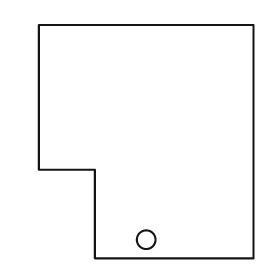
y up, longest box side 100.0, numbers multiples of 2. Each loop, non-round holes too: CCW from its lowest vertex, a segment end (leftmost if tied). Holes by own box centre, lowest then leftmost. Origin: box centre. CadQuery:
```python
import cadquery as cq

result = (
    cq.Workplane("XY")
    .moveTo(-22.0, -50.0)
    .lineTo(46.0, -50.0)
    .lineTo(46.0, 50.0)
    .lineTo(-46.0, 50.0)
    .lineTo(-46.0, -12.0)
    .lineTo(-22.0, -12.0)
    .close()
    .moveTo(0.0, -42.0)
    .circle(4.0)
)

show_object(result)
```